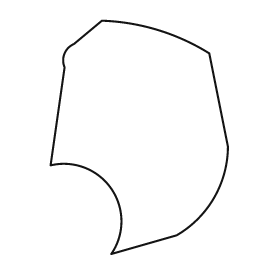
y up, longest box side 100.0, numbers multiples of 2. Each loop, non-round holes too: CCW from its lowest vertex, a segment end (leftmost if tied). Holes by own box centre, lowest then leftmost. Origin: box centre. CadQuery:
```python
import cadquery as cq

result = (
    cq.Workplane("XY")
    .moveTo(-12.0, -50.0)
    .lineTo(16.0, -42.0)
    .threePointArc((32.0, -26.0), (38.0, -4.0))
    .lineTo(30.0, 36.0)
    .threePointArc((8.0, 46.0), (-16.0, 50.0))
    .lineTo(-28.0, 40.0)
    .threePointArc((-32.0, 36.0), (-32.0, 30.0))
    .lineTo(-38.0, -12.0)
    .threePointArc((-12.0, -22.0), (-12.0, -50.0))
    .close()
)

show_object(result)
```